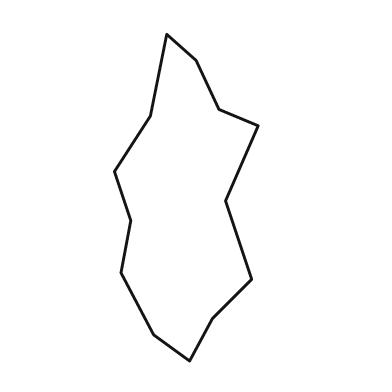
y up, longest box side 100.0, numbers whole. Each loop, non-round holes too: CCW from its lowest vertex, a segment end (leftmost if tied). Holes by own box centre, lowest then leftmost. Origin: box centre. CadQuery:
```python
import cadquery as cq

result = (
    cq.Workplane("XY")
    .moveTo(1.0, -50.0)
    .lineTo(8.0, -37.0)
    .lineTo(20.0, -25.0)
    .lineTo(12.0, -1.0)
    .lineTo(22.0, 22.0)
    .lineTo(10.0, 27.0)
    .lineTo(3.0, 42.0)
    .lineTo(-6.0, 50.0)
    .lineTo(-11.0, 25.0)
    .lineTo(-22.0, 8.0)
    .lineTo(-17.0, -7.0)
    .lineTo(-20.0, -23.0)
    .lineTo(-10.0, -42.0)
    .close()
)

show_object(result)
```